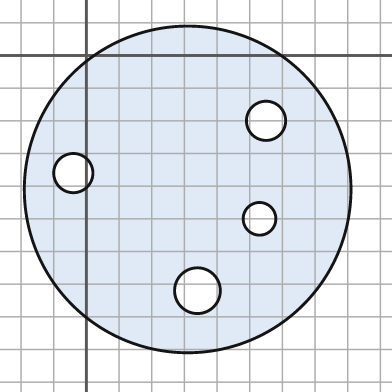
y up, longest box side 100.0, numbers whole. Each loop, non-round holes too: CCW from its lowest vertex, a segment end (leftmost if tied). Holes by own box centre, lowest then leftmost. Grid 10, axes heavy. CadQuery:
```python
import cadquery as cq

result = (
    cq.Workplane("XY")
    .moveTo(31.0, -41.0)
    .circle(50.0)
    .moveTo(34.0, -72.0)
    .circle(7.0)
    .moveTo(53.0, -50.0)
    .circle(5.0)
    .moveTo(-4.0, -36.0)
    .circle(6.0)
    .moveTo(55.0, -20.0)
    .circle(6.0)
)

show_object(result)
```